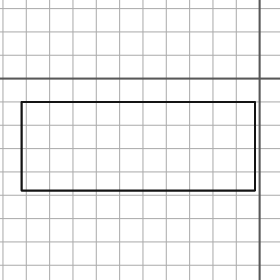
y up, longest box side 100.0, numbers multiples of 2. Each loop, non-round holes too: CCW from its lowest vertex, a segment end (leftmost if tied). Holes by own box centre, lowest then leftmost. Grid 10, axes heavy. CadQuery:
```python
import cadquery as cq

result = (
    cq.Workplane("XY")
    .moveTo(-102.0, -48.0)
    .lineTo(-2.0, -48.0)
    .lineTo(-2.0, -10.0)
    .lineTo(-102.0, -10.0)
    .close()
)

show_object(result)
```